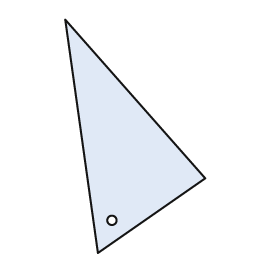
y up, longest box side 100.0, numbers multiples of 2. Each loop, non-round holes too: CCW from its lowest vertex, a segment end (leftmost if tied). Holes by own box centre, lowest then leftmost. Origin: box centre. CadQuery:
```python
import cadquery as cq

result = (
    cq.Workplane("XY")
    .moveTo(-16.0, -50.0)
    .lineTo(30.0, -18.0)
    .lineTo(-30.0, 50.0)
    .close()
    .moveTo(-10.0, -36.0)
    .circle(2.0)
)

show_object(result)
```